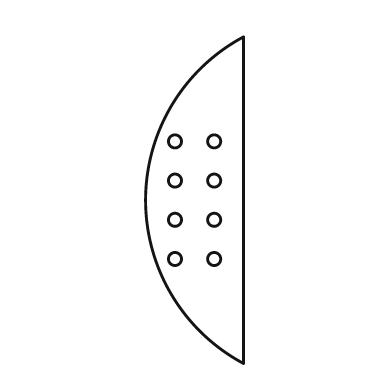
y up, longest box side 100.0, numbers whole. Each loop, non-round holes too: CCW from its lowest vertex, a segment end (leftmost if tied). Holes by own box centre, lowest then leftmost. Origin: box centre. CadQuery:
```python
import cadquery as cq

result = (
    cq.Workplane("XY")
    .moveTo(15.0, -50.0)
    .lineTo(15.0, 50.0)
    .threePointArc((-15.0, 0.0), (15.0, -50.0))
    .close()
    .moveTo(-6.0, -18.0)
    .circle(2.0)
    .moveTo(6.0, -18.0)
    .circle(2.0)
    .moveTo(-6.0, -6.0)
    .circle(2.0)
    .moveTo(6.0, -6.0)
    .circle(2.0)
    .moveTo(-6.0, 6.0)
    .circle(2.0)
    .moveTo(6.0, 6.0)
    .circle(2.0)
    .moveTo(-6.0, 18.0)
    .circle(2.0)
    .moveTo(6.0, 18.0)
    .circle(2.0)
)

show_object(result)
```